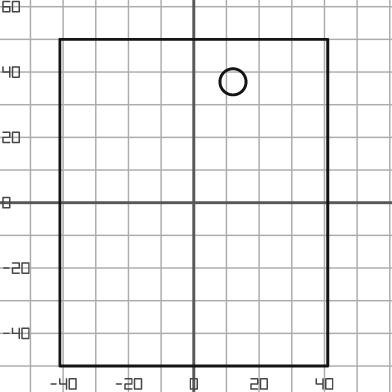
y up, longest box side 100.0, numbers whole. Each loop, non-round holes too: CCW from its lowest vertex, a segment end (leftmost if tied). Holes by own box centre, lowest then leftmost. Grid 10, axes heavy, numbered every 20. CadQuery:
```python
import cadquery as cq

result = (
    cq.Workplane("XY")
    .moveTo(-41.0, -50.0)
    .lineTo(41.0, -50.0)
    .lineTo(41.0, 50.0)
    .lineTo(-41.0, 50.0)
    .close()
    .moveTo(12.0, 37.0)
    .circle(4.0)
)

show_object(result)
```